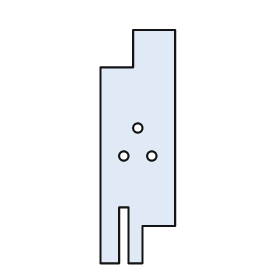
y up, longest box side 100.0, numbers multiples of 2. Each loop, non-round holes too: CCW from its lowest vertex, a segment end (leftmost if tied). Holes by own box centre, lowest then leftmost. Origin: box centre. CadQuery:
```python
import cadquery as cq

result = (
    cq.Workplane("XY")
    .moveTo(-16.0, -50.0)
    .lineTo(-8.0, -50.0)
    .lineTo(-8.0, -26.0)
    .lineTo(-4.0, -26.0)
    .lineTo(-4.0, -50.0)
    .lineTo(2.0, -50.0)
    .lineTo(2.0, -34.0)
    .lineTo(16.0, -34.0)
    .lineTo(16.0, 50.0)
    .lineTo(-2.0, 50.0)
    .lineTo(-2.0, 34.0)
    .lineTo(-16.0, 34.0)
    .close()
    .moveTo(-6.0, -4.0)
    .circle(2.0)
    .moveTo(6.0, -4.0)
    .circle(2.0)
    .moveTo(0.0, 8.0)
    .circle(2.0)
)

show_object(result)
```